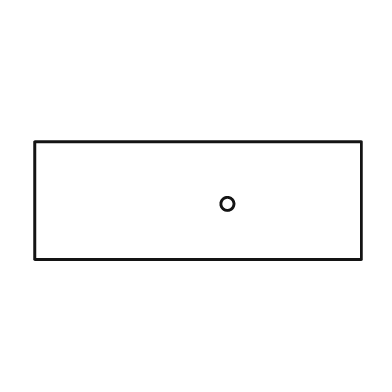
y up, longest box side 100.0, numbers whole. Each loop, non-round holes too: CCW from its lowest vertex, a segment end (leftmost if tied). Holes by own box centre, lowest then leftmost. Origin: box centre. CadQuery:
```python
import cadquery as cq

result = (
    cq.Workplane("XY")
    .moveTo(-50.0, -18.0)
    .lineTo(50.0, -18.0)
    .lineTo(50.0, 18.0)
    .lineTo(-50.0, 18.0)
    .close()
    .moveTo(9.0, -1.0)
    .circle(2.0)
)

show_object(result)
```